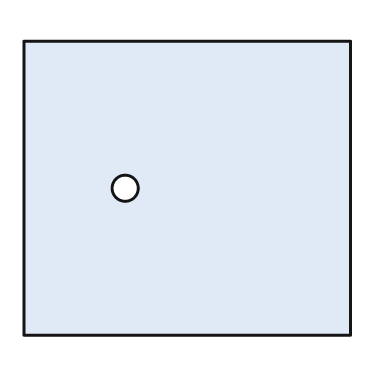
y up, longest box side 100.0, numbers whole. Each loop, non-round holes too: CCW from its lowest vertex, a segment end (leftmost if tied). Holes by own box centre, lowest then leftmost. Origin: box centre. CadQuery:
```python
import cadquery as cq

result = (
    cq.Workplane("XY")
    .moveTo(-50.0, -45.0)
    .lineTo(50.0, -45.0)
    .lineTo(50.0, 45.0)
    .lineTo(-50.0, 45.0)
    .close()
    .moveTo(-19.0, 0.0)
    .circle(4.0)
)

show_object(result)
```